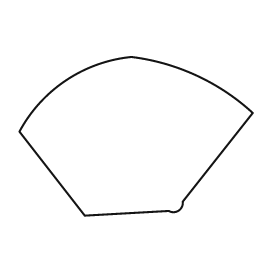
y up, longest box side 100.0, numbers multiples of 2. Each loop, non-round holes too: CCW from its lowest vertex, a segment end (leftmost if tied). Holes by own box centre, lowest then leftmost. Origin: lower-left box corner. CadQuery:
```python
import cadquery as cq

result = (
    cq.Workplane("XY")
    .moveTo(28.0, 0.0)
    .lineTo(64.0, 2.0)
    .threePointArc((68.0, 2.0), (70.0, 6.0))
    .lineTo(100.0, 44.0)
    .threePointArc((76.0, 60.0), (48.0, 68.0))
    .threePointArc((20.0, 58.0), (0.0, 36.0))
    .close()
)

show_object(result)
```